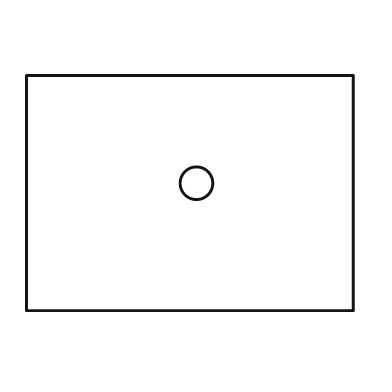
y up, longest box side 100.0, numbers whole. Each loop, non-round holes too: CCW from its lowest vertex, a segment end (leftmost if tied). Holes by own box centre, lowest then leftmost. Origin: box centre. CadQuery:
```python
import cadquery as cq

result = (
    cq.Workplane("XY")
    .moveTo(-50.0, -36.0)
    .lineTo(50.0, -36.0)
    .lineTo(50.0, 36.0)
    .lineTo(-50.0, 36.0)
    .close()
    .moveTo(2.0, 3.0)
    .circle(5.0)
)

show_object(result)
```